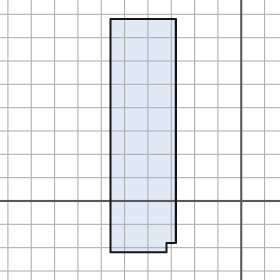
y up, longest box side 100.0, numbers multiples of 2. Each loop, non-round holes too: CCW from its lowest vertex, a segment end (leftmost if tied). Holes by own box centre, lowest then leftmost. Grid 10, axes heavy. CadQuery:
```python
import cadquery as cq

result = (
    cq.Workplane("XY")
    .moveTo(-56.0, -22.0)
    .lineTo(-32.0, -22.0)
    .lineTo(-32.0, -18.0)
    .lineTo(-28.0, -18.0)
    .lineTo(-28.0, 78.0)
    .lineTo(-56.0, 78.0)
    .close()
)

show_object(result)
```